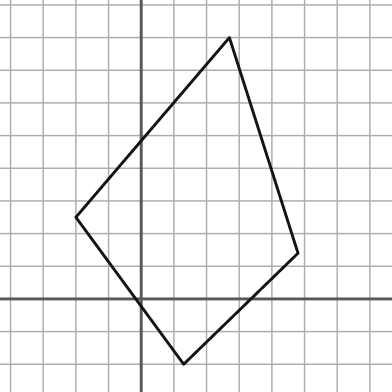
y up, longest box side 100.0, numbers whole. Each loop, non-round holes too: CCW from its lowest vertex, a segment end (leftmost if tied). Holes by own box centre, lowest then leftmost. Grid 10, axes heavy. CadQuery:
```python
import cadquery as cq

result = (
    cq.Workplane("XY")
    .moveTo(13.0, -20.0)
    .lineTo(48.0, 14.0)
    .lineTo(27.0, 80.0)
    .lineTo(-20.0, 25.0)
    .close()
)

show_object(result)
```